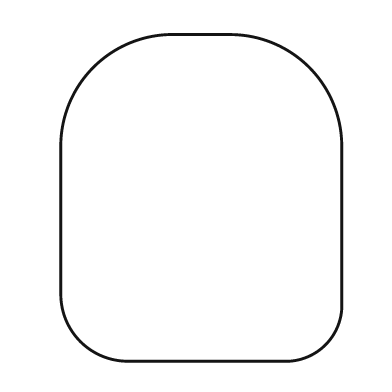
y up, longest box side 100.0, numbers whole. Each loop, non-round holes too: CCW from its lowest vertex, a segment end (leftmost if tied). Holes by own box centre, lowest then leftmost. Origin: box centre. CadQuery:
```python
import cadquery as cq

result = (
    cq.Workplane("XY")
    .moveTo(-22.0, -50.0)
    .lineTo(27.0, -50.0)
    .threePointArc((38.0, -45.0), (43.0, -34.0))
    .lineTo(43.0, 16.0)
    .threePointArc((33.0, 40.0), (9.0, 50.0))
    .lineTo(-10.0, 50.0)
    .threePointArc((-33.0, 40.0), (-43.0, 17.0))
    .lineTo(-43.0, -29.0)
    .threePointArc((-37.0, -44.0), (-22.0, -50.0))
    .close()
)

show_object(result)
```